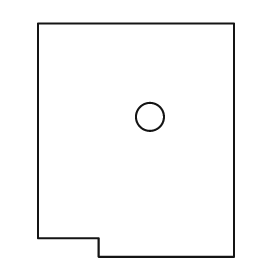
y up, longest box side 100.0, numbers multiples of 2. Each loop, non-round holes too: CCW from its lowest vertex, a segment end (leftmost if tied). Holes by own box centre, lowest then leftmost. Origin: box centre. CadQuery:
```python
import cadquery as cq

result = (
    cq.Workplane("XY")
    .moveTo(-16.0, -50.0)
    .lineTo(42.0, -50.0)
    .lineTo(42.0, 50.0)
    .lineTo(-42.0, 50.0)
    .lineTo(-42.0, -42.0)
    .lineTo(-16.0, -42.0)
    .close()
    .moveTo(6.0, 10.0)
    .circle(6.0)
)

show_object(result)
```